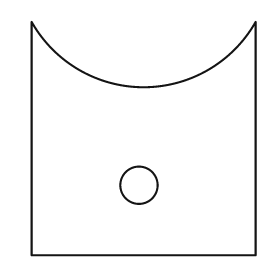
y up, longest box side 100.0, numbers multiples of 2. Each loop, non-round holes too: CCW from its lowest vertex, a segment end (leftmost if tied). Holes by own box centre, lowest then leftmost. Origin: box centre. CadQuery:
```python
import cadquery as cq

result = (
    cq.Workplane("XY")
    .moveTo(-48.0, -50.0)
    .lineTo(48.0, -50.0)
    .lineTo(48.0, 50.0)
    .threePointArc((0.0, 22.0), (-48.0, 50.0))
    .close()
    .moveTo(-2.0, -20.0)
    .circle(8.0)
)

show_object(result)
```